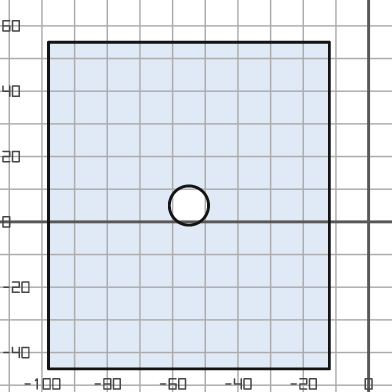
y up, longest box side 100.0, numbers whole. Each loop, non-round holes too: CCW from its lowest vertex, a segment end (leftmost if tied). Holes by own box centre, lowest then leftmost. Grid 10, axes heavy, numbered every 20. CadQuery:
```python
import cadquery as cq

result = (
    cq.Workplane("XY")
    .moveTo(-98.0, -45.0)
    .lineTo(-12.0, -45.0)
    .lineTo(-12.0, 55.0)
    .lineTo(-98.0, 55.0)
    .close()
    .moveTo(-55.0, 5.0)
    .circle(6.0)
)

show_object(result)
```